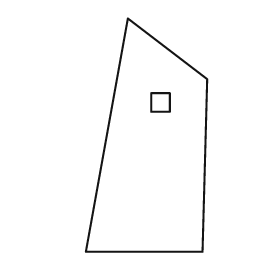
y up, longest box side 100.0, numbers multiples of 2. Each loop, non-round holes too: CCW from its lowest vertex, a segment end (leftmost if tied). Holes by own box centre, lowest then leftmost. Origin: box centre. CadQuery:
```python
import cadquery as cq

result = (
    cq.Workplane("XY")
    .moveTo(-26.0, -50.0)
    .lineTo(24.0, -50.0)
    .lineTo(26.0, 24.0)
    .lineTo(-8.0, 50.0)
    .close()
    .moveTo(2.0, 10.0)
    .lineTo(10.0, 10.0)
    .lineTo(10.0, 18.0)
    .lineTo(2.0, 18.0)
    .close()
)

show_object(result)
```